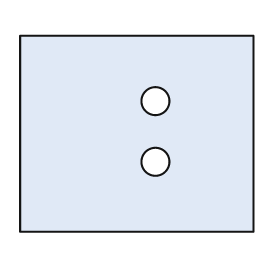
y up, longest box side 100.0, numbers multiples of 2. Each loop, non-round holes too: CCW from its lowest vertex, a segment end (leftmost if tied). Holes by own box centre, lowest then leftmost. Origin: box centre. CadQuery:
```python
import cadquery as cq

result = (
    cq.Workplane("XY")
    .moveTo(-50.0, -42.0)
    .lineTo(50.0, -42.0)
    .lineTo(50.0, 42.0)
    .lineTo(-50.0, 42.0)
    .close()
    .moveTo(8.0, -12.0)
    .circle(6.0)
    .moveTo(8.0, 14.0)
    .circle(6.0)
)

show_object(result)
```